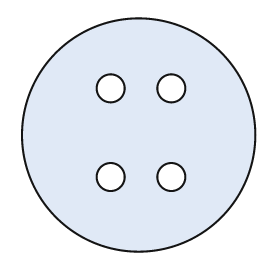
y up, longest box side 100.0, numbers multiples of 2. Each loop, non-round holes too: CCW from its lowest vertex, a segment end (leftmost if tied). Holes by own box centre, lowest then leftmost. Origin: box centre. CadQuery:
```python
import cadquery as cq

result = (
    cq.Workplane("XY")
    .moveTo(0.0, 0.0)
    .circle(50.0)
    .moveTo(-12.0, -18.0)
    .circle(6.0)
    .moveTo(14.0, -18.0)
    .circle(6.0)
    .moveTo(-12.0, 20.0)
    .circle(6.0)
    .moveTo(14.0, 20.0)
    .circle(6.0)
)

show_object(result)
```